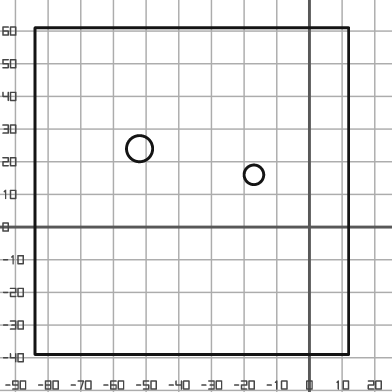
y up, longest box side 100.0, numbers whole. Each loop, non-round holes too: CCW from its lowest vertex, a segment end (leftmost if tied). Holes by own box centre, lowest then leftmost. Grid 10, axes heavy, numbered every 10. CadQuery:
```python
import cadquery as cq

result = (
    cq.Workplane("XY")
    .moveTo(-84.0, -39.0)
    .lineTo(12.0, -39.0)
    .lineTo(12.0, 61.0)
    .lineTo(-84.0, 61.0)
    .close()
    .moveTo(-17.0, 16.0)
    .circle(3.0)
    .moveTo(-52.0, 24.0)
    .circle(4.0)
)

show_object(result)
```